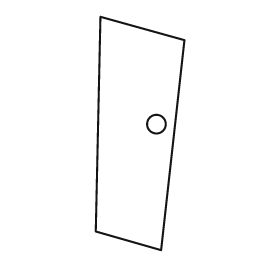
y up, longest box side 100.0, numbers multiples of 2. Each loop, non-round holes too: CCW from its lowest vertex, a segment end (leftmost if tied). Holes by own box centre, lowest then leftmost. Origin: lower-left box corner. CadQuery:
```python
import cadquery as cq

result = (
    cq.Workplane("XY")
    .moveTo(28.0, 0.0)
    .lineTo(38.0, 90.0)
    .lineTo(2.0, 100.0)
    .lineTo(0.0, 8.0)
    .close()
    .moveTo(26.0, 54.0)
    .circle(4.0)
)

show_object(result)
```